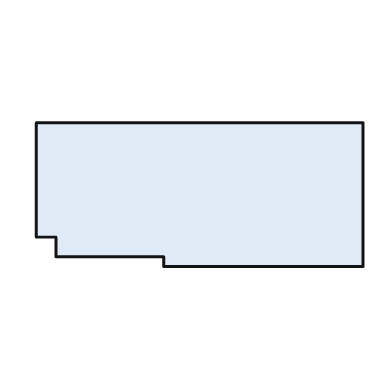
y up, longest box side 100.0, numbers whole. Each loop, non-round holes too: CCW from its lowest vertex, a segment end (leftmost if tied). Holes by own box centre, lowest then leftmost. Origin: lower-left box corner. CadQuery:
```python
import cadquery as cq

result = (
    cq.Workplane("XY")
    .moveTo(39.0, 0.0)
    .lineTo(100.0, 0.0)
    .lineTo(100.0, 44.0)
    .lineTo(0.0, 44.0)
    .lineTo(0.0, 9.0)
    .lineTo(6.0, 9.0)
    .lineTo(6.0, 3.0)
    .lineTo(39.0, 3.0)
    .close()
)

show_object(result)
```